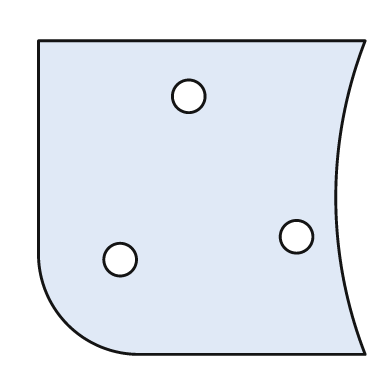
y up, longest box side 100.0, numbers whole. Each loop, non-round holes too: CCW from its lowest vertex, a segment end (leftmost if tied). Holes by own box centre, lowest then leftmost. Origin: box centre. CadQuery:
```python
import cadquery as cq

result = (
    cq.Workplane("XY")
    .moveTo(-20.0, -48.0)
    .lineTo(50.0, -48.0)
    .threePointArc((41.0, 0.0), (50.0, 48.0))
    .lineTo(-50.0, 48.0)
    .lineTo(-50.0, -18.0)
    .threePointArc((-41.0, -39.0), (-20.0, -48.0))
    .close()
    .moveTo(-25.0, -19.0)
    .circle(5.0)
    .moveTo(29.0, -12.0)
    .circle(5.0)
    .moveTo(-4.0, 31.0)
    .circle(5.0)
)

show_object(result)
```